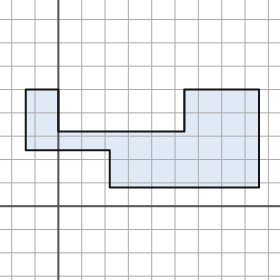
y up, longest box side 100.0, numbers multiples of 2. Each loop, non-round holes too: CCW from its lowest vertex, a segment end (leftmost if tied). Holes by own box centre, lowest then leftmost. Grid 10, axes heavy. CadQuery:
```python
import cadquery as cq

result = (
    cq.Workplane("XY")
    .moveTo(22.0, 8.0)
    .lineTo(86.0, 8.0)
    .lineTo(86.0, 50.0)
    .lineTo(54.0, 50.0)
    .lineTo(54.0, 32.0)
    .lineTo(0.0, 32.0)
    .lineTo(0.0, 50.0)
    .lineTo(-14.0, 50.0)
    .lineTo(-14.0, 24.0)
    .lineTo(22.0, 24.0)
    .close()
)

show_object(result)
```